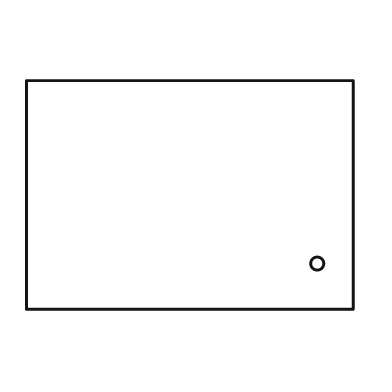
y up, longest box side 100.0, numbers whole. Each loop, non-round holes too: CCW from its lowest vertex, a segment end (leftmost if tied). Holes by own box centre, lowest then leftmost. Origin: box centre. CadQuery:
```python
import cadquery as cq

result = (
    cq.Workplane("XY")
    .moveTo(-50.0, -35.0)
    .lineTo(50.0, -35.0)
    .lineTo(50.0, 35.0)
    .lineTo(-50.0, 35.0)
    .close()
    .moveTo(39.0, -21.0)
    .circle(2.0)
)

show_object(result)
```